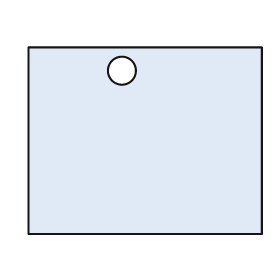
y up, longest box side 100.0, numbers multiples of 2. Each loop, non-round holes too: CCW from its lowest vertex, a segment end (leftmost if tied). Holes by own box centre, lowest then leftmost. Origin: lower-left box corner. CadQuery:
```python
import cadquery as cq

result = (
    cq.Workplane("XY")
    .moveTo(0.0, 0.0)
    .lineTo(100.0, 0.0)
    .lineTo(100.0, 80.0)
    .lineTo(0.0, 80.0)
    .close()
    .moveTo(40.0, 70.0)
    .circle(6.0)
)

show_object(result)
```